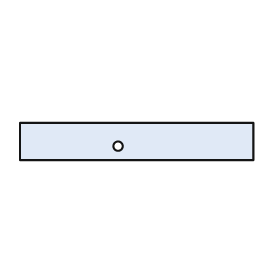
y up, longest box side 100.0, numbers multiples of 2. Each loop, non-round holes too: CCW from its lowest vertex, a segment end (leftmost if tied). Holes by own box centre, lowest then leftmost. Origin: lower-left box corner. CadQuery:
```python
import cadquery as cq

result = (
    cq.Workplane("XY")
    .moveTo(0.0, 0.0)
    .lineTo(100.0, 0.0)
    .lineTo(100.0, 16.0)
    .lineTo(0.0, 16.0)
    .close()
    .moveTo(42.0, 6.0)
    .circle(2.0)
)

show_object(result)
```